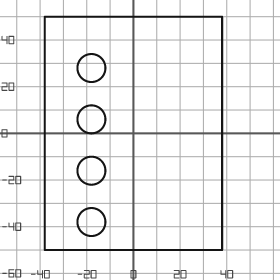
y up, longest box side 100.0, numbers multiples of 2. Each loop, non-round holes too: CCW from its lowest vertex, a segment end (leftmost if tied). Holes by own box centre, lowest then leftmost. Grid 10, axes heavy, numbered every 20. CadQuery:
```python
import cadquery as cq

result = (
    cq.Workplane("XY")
    .moveTo(-38.0, -50.0)
    .lineTo(38.0, -50.0)
    .lineTo(38.0, 50.0)
    .lineTo(-38.0, 50.0)
    .close()
    .moveTo(-18.0, -38.0)
    .circle(6.0)
    .moveTo(-18.0, -16.0)
    .circle(6.0)
    .moveTo(-18.0, 6.0)
    .circle(6.0)
    .moveTo(-18.0, 28.0)
    .circle(6.0)
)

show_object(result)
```